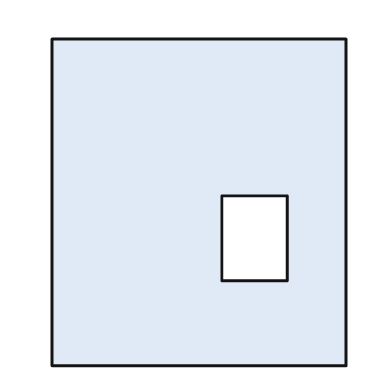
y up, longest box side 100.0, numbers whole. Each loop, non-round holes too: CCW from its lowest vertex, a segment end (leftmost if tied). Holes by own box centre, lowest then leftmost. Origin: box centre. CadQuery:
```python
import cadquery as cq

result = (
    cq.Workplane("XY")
    .moveTo(-45.0, -50.0)
    .lineTo(45.0, -50.0)
    .lineTo(45.0, 50.0)
    .lineTo(-45.0, 50.0)
    .close()
    .moveTo(7.0, -24.0)
    .lineTo(27.0, -24.0)
    .lineTo(27.0, 2.0)
    .lineTo(7.0, 2.0)
    .close()
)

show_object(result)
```